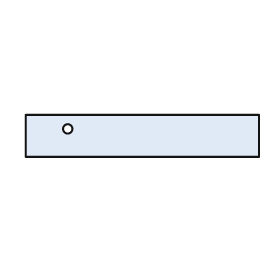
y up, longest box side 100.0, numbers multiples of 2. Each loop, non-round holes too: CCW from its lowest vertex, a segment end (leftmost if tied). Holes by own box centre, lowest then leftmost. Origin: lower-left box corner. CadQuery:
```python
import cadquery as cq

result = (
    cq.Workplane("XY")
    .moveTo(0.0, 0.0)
    .lineTo(100.0, 0.0)
    .lineTo(100.0, 18.0)
    .lineTo(0.0, 18.0)
    .close()
    .moveTo(18.0, 12.0)
    .circle(2.0)
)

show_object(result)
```